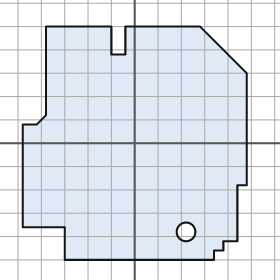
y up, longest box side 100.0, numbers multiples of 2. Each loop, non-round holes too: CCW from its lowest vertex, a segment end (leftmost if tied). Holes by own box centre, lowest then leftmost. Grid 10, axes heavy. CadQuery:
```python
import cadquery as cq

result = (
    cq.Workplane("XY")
    .moveTo(-30.0, -50.0)
    .lineTo(34.0, -50.0)
    .lineTo(34.0, -46.0)
    .lineTo(38.0, -46.0)
    .lineTo(38.0, -42.0)
    .lineTo(44.0, -42.0)
    .lineTo(44.0, -18.0)
    .lineTo(48.0, -18.0)
    .lineTo(48.0, 30.0)
    .lineTo(28.0, 50.0)
    .lineTo(-4.0, 50.0)
    .lineTo(-4.0, 38.0)
    .lineTo(-10.0, 38.0)
    .lineTo(-10.0, 50.0)
    .lineTo(-38.0, 50.0)
    .lineTo(-38.0, 12.0)
    .lineTo(-42.0, 8.0)
    .lineTo(-48.0, 8.0)
    .lineTo(-48.0, -36.0)
    .lineTo(-30.0, -36.0)
    .close()
    .moveTo(22.0, -38.0)
    .circle(4.0)
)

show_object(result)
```